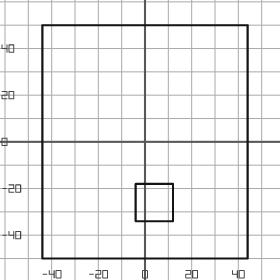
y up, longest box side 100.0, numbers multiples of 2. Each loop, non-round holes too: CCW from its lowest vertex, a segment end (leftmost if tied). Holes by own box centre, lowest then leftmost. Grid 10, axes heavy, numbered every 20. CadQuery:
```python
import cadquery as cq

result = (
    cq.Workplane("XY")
    .moveTo(-44.0, -50.0)
    .lineTo(44.0, -50.0)
    .lineTo(44.0, 50.0)
    .lineTo(-44.0, 50.0)
    .close()
    .moveTo(-4.0, -34.0)
    .lineTo(12.0, -34.0)
    .lineTo(12.0, -18.0)
    .lineTo(-4.0, -18.0)
    .close()
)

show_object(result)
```